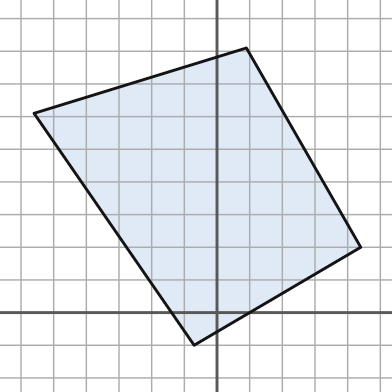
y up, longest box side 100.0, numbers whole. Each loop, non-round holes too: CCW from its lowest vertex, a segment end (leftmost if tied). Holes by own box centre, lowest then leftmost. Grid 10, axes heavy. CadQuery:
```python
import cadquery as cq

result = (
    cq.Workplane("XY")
    .moveTo(-7.0, -10.0)
    .lineTo(44.0, 20.0)
    .lineTo(9.0, 81.0)
    .lineTo(-56.0, 61.0)
    .close()
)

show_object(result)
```